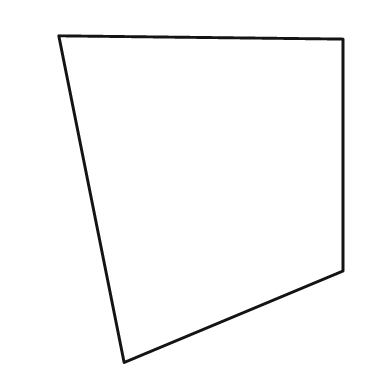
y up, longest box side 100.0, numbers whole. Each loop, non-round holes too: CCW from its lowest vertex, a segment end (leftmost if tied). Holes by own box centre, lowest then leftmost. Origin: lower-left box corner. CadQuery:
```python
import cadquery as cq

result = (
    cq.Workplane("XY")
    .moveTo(20.0, 0.0)
    .lineTo(87.0, 28.0)
    .lineTo(87.0, 99.0)
    .lineTo(0.0, 100.0)
    .close()
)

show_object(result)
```